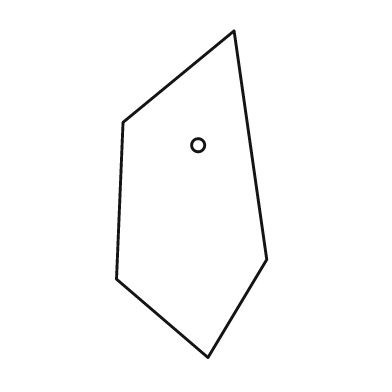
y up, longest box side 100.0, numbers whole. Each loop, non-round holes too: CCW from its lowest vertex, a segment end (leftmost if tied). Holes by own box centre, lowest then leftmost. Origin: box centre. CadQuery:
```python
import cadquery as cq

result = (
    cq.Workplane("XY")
    .moveTo(5.0, -50.0)
    .lineTo(23.0, -20.0)
    .lineTo(13.0, 50.0)
    .lineTo(-21.0, 22.0)
    .lineTo(-23.0, -26.0)
    .close()
    .moveTo(2.0, 15.0)
    .circle(2.0)
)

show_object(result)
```